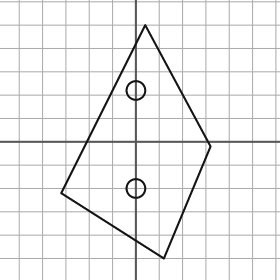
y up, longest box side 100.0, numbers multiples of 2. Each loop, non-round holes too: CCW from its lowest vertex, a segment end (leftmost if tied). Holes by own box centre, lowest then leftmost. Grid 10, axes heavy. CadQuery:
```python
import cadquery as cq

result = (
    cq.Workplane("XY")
    .moveTo(12.0, -50.0)
    .lineTo(32.0, -2.0)
    .lineTo(4.0, 50.0)
    .lineTo(-32.0, -22.0)
    .close()
    .moveTo(0.0, -20.0)
    .circle(4.0)
    .moveTo(0.0, 22.0)
    .circle(4.0)
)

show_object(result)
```